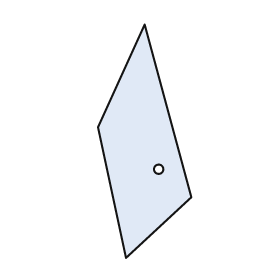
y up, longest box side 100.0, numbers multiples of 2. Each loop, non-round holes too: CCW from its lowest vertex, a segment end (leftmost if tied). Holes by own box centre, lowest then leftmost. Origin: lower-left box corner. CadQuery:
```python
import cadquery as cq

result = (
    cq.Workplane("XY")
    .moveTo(12.0, 0.0)
    .lineTo(40.0, 26.0)
    .lineTo(20.0, 100.0)
    .lineTo(0.0, 56.0)
    .close()
    .moveTo(26.0, 38.0)
    .circle(2.0)
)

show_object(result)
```